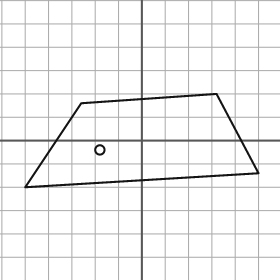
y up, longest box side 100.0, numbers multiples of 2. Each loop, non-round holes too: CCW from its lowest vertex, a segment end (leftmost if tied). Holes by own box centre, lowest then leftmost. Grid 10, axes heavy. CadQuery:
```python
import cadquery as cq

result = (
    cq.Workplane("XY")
    .moveTo(-50.0, -20.0)
    .lineTo(50.0, -14.0)
    .lineTo(32.0, 20.0)
    .lineTo(-26.0, 16.0)
    .close()
    .moveTo(-18.0, -4.0)
    .circle(2.0)
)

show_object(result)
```